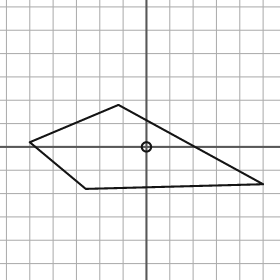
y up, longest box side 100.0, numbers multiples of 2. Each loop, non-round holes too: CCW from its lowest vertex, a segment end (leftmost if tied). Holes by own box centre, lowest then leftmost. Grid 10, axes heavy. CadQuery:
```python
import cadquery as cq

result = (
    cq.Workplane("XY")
    .moveTo(-26.0, -18.0)
    .lineTo(50.0, -16.0)
    .lineTo(-12.0, 18.0)
    .lineTo(-50.0, 2.0)
    .close()
    .moveTo(0.0, 0.0)
    .circle(2.0)
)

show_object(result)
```